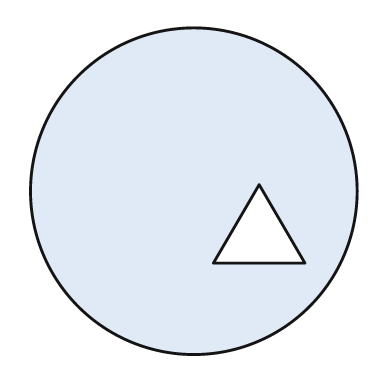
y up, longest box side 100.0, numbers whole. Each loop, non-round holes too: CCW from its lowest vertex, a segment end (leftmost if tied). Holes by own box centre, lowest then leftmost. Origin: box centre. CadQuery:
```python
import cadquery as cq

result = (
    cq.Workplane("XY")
    .moveTo(0.0, 0.0)
    .circle(50.0)
    .moveTo(6.0, -22.0)
    .lineTo(34.0, -22.0)
    .lineTo(20.0, 2.0)
    .close()
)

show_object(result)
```